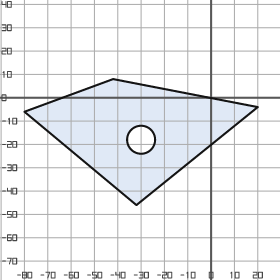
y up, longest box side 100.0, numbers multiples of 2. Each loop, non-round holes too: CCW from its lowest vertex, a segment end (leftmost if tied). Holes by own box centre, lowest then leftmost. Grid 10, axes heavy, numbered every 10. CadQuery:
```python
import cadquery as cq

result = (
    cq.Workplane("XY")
    .moveTo(-32.0, -46.0)
    .lineTo(20.0, -4.0)
    .lineTo(-42.0, 8.0)
    .lineTo(-80.0, -6.0)
    .close()
    .moveTo(-30.0, -18.0)
    .circle(6.0)
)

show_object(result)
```